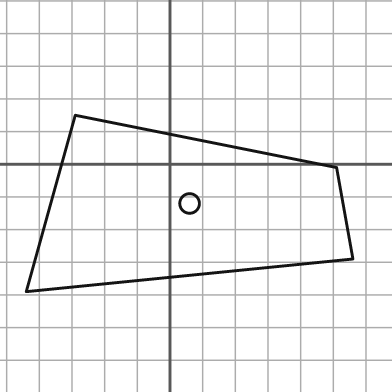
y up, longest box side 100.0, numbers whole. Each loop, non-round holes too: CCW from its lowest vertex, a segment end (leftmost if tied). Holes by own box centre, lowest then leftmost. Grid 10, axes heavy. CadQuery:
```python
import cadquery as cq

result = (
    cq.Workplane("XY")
    .moveTo(-44.0, -39.0)
    .lineTo(56.0, -29.0)
    .lineTo(51.0, -1.0)
    .lineTo(-29.0, 15.0)
    .close()
    .moveTo(6.0, -12.0)
    .circle(3.0)
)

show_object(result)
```